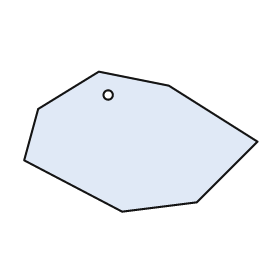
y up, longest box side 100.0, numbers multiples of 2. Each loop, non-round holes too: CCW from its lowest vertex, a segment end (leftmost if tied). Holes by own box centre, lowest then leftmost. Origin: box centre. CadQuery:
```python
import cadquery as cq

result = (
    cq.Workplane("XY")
    .moveTo(-8.0, -30.0)
    .lineTo(24.0, -26.0)
    .lineTo(50.0, 0.0)
    .lineTo(12.0, 24.0)
    .lineTo(-18.0, 30.0)
    .lineTo(-44.0, 14.0)
    .lineTo(-50.0, -8.0)
    .close()
    .moveTo(-14.0, 20.0)
    .circle(2.0)
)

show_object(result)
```